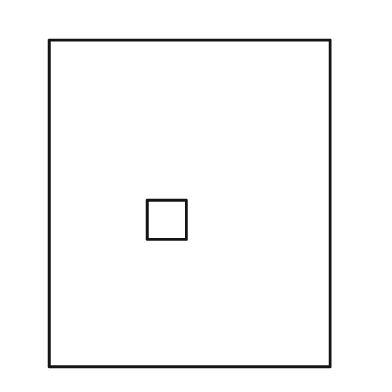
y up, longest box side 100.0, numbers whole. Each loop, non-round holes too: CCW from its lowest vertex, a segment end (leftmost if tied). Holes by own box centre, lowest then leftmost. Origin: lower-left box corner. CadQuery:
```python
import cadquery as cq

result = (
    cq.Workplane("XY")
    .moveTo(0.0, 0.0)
    .lineTo(86.0, 0.0)
    .lineTo(86.0, 100.0)
    .lineTo(0.0, 100.0)
    .close()
    .moveTo(30.0, 39.0)
    .lineTo(42.0, 39.0)
    .lineTo(42.0, 51.0)
    .lineTo(30.0, 51.0)
    .close()
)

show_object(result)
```